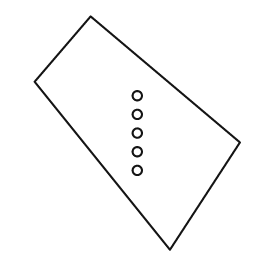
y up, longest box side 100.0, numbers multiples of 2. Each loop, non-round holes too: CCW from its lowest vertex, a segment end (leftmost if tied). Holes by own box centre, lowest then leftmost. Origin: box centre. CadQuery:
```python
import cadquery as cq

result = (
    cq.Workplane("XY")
    .moveTo(14.0, -50.0)
    .lineTo(44.0, -4.0)
    .lineTo(-20.0, 50.0)
    .lineTo(-44.0, 22.0)
    .close()
    .moveTo(0.0, -16.0)
    .circle(2.0)
    .moveTo(0.0, -8.0)
    .circle(2.0)
    .moveTo(0.0, 0.0)
    .circle(2.0)
    .moveTo(0.0, 8.0)
    .circle(2.0)
    .moveTo(0.0, 16.0)
    .circle(2.0)
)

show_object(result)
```